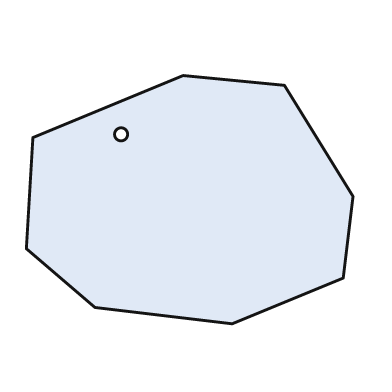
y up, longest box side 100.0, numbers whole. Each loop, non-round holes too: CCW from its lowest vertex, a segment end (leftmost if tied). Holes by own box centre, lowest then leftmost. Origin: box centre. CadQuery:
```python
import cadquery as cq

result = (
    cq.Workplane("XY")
    .moveTo(13.0, -38.0)
    .lineTo(47.0, -24.0)
    .lineTo(50.0, 1.0)
    .lineTo(29.0, 35.0)
    .lineTo(-2.0, 38.0)
    .lineTo(-48.0, 19.0)
    .lineTo(-50.0, -15.0)
    .lineTo(-29.0, -33.0)
    .close()
    .moveTo(-21.0, 20.0)
    .circle(2.0)
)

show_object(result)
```